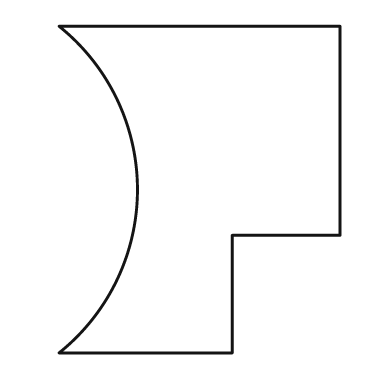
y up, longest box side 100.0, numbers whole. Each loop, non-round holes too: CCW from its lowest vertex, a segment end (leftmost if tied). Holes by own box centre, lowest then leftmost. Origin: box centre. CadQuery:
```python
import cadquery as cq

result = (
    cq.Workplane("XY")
    .moveTo(-43.0, -50.0)
    .lineTo(10.0, -50.0)
    .lineTo(10.0, -14.0)
    .lineTo(43.0, -14.0)
    .lineTo(43.0, 50.0)
    .lineTo(-43.0, 50.0)
    .threePointArc((-19.0, 0.0), (-43.0, -50.0))
    .close()
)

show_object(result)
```